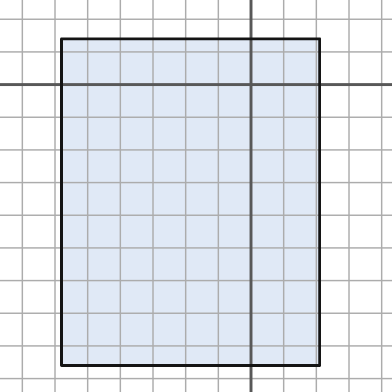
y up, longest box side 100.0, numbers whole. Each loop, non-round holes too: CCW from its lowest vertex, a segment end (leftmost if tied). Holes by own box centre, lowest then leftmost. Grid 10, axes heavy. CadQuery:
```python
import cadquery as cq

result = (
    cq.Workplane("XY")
    .moveTo(-58.0, -86.0)
    .lineTo(21.0, -86.0)
    .lineTo(21.0, 14.0)
    .lineTo(-58.0, 14.0)
    .close()
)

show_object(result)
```